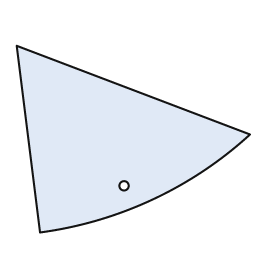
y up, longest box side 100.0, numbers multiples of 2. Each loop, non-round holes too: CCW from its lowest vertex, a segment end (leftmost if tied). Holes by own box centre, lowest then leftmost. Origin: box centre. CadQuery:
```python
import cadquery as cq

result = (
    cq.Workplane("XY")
    .moveTo(-40.0, -40.0)
    .threePointArc((8.0, -26.0), (50.0, 2.0))
    .lineTo(-50.0, 40.0)
    .close()
    .moveTo(-4.0, -20.0)
    .circle(2.0)
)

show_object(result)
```